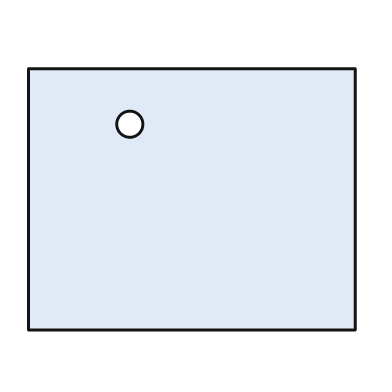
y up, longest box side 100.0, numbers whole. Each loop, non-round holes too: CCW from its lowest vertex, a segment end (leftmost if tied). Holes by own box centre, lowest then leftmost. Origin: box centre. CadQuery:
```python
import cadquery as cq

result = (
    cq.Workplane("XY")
    .moveTo(-50.0, -40.0)
    .lineTo(50.0, -40.0)
    .lineTo(50.0, 40.0)
    .lineTo(-50.0, 40.0)
    .close()
    .moveTo(-19.0, 23.0)
    .circle(4.0)
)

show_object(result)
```